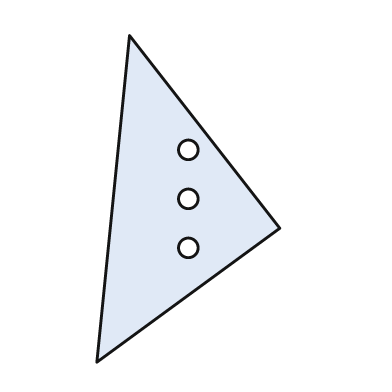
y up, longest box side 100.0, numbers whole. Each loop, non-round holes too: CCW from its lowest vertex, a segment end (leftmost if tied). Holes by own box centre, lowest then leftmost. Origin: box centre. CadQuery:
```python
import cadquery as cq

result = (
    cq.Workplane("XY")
    .moveTo(-28.0, -50.0)
    .lineTo(28.0, -9.0)
    .lineTo(-18.0, 50.0)
    .close()
    .moveTo(0.0, -15.0)
    .circle(3.0)
    .moveTo(0.0, 0.0)
    .circle(3.0)
    .moveTo(0.0, 15.0)
    .circle(3.0)
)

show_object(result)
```